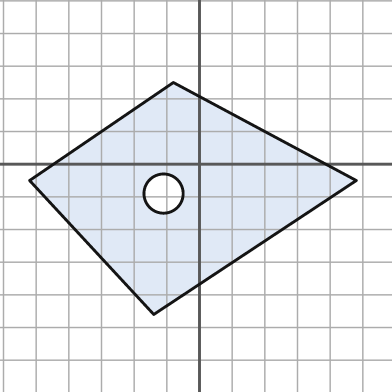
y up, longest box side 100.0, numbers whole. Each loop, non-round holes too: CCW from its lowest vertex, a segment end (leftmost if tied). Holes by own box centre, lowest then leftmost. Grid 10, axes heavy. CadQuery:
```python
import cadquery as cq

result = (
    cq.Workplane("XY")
    .moveTo(-14.0, -46.0)
    .lineTo(48.0, -5.0)
    .lineTo(-8.0, 25.0)
    .lineTo(-52.0, -5.0)
    .close()
    .moveTo(-11.0, -9.0)
    .circle(6.0)
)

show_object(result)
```